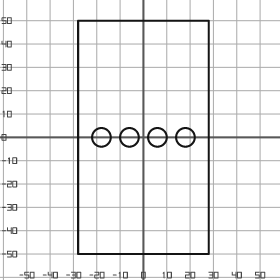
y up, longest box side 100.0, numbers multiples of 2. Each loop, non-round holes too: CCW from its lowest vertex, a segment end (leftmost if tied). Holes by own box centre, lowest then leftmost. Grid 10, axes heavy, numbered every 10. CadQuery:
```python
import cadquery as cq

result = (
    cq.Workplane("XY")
    .moveTo(-28.0, -50.0)
    .lineTo(28.0, -50.0)
    .lineTo(28.0, 50.0)
    .lineTo(-28.0, 50.0)
    .close()
    .moveTo(-18.0, 0.0)
    .circle(4.0)
    .moveTo(-6.0, 0.0)
    .circle(4.0)
    .moveTo(6.0, 0.0)
    .circle(4.0)
    .moveTo(18.0, 0.0)
    .circle(4.0)
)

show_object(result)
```